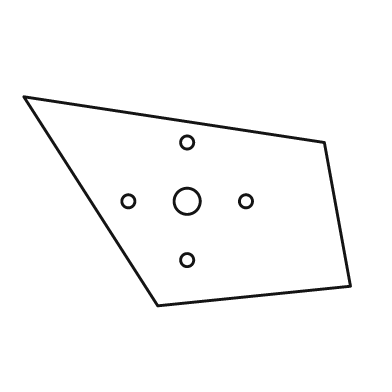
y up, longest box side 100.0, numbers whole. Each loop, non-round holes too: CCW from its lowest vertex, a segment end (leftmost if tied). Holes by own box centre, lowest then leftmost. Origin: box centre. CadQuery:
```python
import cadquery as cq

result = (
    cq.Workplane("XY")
    .moveTo(-9.0, -32.0)
    .lineTo(50.0, -26.0)
    .lineTo(42.0, 18.0)
    .lineTo(-50.0, 32.0)
    .close()
    .moveTo(0.0, -18.0)
    .circle(2.0)
    .moveTo(-18.0, 0.0)
    .circle(2.0)
    .moveTo(0.0, 0.0)
    .circle(4.0)
    .moveTo(18.0, 0.0)
    .circle(2.0)
    .moveTo(0.0, 18.0)
    .circle(2.0)
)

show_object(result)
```